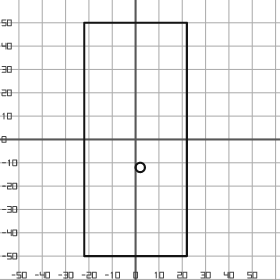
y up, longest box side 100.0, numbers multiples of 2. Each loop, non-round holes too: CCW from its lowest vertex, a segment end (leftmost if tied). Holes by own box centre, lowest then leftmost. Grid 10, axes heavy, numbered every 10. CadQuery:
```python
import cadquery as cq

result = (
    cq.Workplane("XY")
    .moveTo(-22.0, -50.0)
    .lineTo(22.0, -50.0)
    .lineTo(22.0, 50.0)
    .lineTo(-22.0, 50.0)
    .close()
    .moveTo(2.0, -12.0)
    .circle(2.0)
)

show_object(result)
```